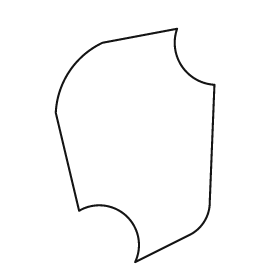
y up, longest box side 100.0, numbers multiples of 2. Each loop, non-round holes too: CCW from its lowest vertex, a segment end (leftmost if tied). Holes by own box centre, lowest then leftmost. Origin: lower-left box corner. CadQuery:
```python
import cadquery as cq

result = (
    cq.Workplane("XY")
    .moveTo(34.0, 0.0)
    .lineTo(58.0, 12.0)
    .threePointArc((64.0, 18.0), (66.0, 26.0))
    .lineTo(68.0, 76.0)
    .threePointArc((54.0, 84.0), (52.0, 100.0))
    .lineTo(20.0, 94.0)
    .threePointArc((6.0, 82.0), (0.0, 64.0))
    .lineTo(10.0, 22.0)
    .threePointArc((30.0, 20.0), (34.0, 0.0))
    .close()
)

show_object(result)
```